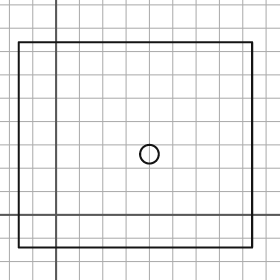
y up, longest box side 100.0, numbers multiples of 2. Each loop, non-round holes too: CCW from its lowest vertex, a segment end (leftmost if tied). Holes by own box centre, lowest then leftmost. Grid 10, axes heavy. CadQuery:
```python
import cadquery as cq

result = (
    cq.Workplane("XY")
    .moveTo(-16.0, -14.0)
    .lineTo(84.0, -14.0)
    .lineTo(84.0, 74.0)
    .lineTo(-16.0, 74.0)
    .close()
    .moveTo(40.0, 26.0)
    .circle(4.0)
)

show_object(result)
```